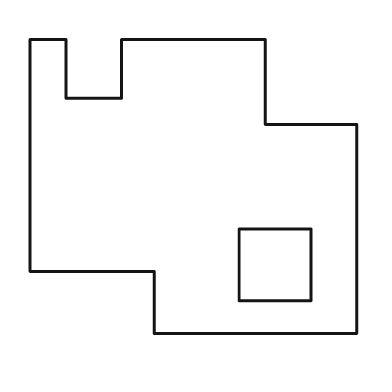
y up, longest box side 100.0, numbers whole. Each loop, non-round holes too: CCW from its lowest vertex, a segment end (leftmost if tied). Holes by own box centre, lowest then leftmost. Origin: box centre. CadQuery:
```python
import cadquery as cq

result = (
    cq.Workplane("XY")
    .moveTo(-12.0, -45.0)
    .lineTo(50.0, -45.0)
    .lineTo(50.0, 19.0)
    .lineTo(22.0, 19.0)
    .lineTo(22.0, 45.0)
    .lineTo(-22.0, 45.0)
    .lineTo(-22.0, 27.0)
    .lineTo(-39.0, 27.0)
    .lineTo(-39.0, 45.0)
    .lineTo(-50.0, 45.0)
    .lineTo(-50.0, -26.0)
    .lineTo(-12.0, -26.0)
    .close()
    .moveTo(14.0, -35.0)
    .lineTo(36.0, -35.0)
    .lineTo(36.0, -13.0)
    .lineTo(14.0, -13.0)
    .close()
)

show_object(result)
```